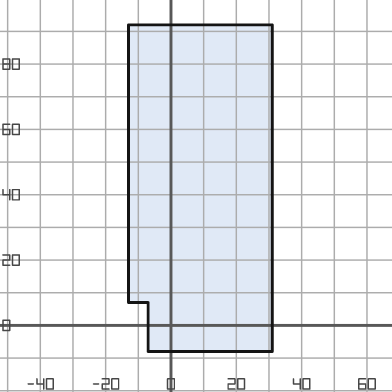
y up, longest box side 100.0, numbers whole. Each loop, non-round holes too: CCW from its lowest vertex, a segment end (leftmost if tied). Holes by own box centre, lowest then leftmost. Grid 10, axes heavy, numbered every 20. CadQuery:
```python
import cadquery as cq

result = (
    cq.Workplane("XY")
    .moveTo(-7.0, -8.0)
    .lineTo(31.0, -8.0)
    .lineTo(31.0, 92.0)
    .lineTo(-13.0, 92.0)
    .lineTo(-13.0, 7.0)
    .lineTo(-7.0, 7.0)
    .close()
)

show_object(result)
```